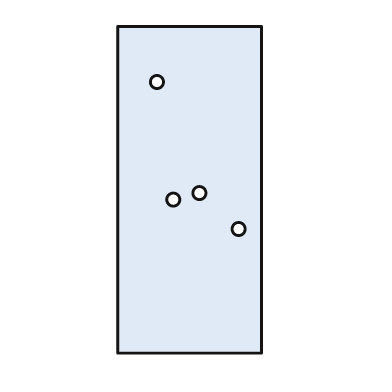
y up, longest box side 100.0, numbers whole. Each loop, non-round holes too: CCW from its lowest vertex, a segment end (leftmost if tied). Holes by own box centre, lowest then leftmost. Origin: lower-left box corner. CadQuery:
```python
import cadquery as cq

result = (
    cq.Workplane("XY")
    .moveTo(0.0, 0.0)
    .lineTo(44.0, 0.0)
    .lineTo(44.0, 100.0)
    .lineTo(0.0, 100.0)
    .close()
    .moveTo(37.0, 38.0)
    .circle(2.0)
    .moveTo(17.0, 47.0)
    .circle(2.0)
    .moveTo(25.0, 49.0)
    .circle(2.0)
    .moveTo(12.0, 83.0)
    .circle(2.0)
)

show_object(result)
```